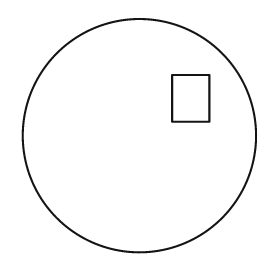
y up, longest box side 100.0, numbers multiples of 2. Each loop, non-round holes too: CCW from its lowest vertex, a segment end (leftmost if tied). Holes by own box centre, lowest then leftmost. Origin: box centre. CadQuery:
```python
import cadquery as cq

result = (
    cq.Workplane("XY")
    .moveTo(0.0, 0.0)
    .circle(50.0)
    .moveTo(14.0, 6.0)
    .lineTo(30.0, 6.0)
    .lineTo(30.0, 26.0)
    .lineTo(14.0, 26.0)
    .close()
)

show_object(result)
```